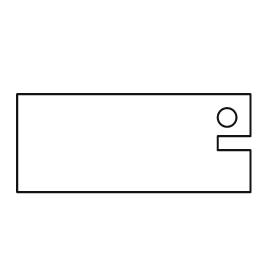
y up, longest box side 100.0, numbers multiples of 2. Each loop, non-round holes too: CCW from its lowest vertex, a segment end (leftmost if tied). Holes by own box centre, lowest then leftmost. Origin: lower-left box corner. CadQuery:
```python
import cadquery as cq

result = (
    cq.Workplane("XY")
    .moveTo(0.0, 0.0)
    .lineTo(100.0, 0.0)
    .lineTo(100.0, 18.0)
    .lineTo(86.0, 18.0)
    .lineTo(86.0, 24.0)
    .lineTo(100.0, 24.0)
    .lineTo(100.0, 42.0)
    .lineTo(0.0, 42.0)
    .close()
    .moveTo(90.0, 32.0)
    .circle(4.0)
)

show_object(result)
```